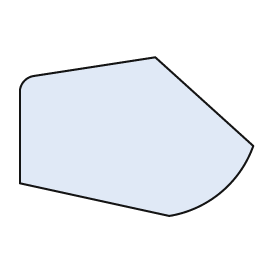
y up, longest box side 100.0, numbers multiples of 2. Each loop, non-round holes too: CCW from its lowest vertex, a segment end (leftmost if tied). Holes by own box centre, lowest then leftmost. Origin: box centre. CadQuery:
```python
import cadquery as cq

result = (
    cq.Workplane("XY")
    .moveTo(14.0, -34.0)
    .threePointArc((36.0, -24.0), (50.0, -4.0))
    .lineTo(8.0, 34.0)
    .lineTo(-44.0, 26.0)
    .threePointArc((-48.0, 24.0), (-50.0, 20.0))
    .lineTo(-50.0, -20.0)
    .close()
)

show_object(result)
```